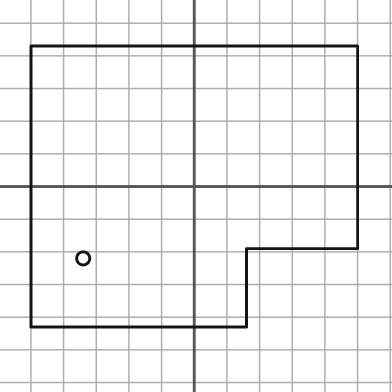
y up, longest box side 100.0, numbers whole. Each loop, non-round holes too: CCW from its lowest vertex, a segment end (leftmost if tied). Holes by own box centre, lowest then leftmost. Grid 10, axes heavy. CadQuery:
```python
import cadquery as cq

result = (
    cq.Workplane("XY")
    .moveTo(-50.0, -43.0)
    .lineTo(16.0, -43.0)
    .lineTo(16.0, -19.0)
    .lineTo(50.0, -19.0)
    .lineTo(50.0, 43.0)
    .lineTo(-50.0, 43.0)
    .close()
    .moveTo(-34.0, -22.0)
    .circle(2.0)
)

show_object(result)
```